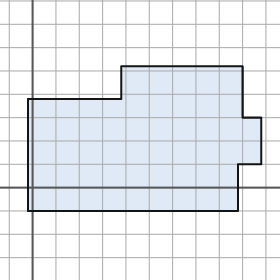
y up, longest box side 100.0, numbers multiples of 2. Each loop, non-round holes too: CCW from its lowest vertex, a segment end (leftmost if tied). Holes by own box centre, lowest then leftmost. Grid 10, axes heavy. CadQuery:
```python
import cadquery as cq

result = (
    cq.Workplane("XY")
    .moveTo(-2.0, -10.0)
    .lineTo(88.0, -10.0)
    .lineTo(88.0, 10.0)
    .lineTo(98.0, 10.0)
    .lineTo(98.0, 30.0)
    .lineTo(90.0, 30.0)
    .lineTo(90.0, 52.0)
    .lineTo(38.0, 52.0)
    .lineTo(38.0, 38.0)
    .lineTo(-2.0, 38.0)
    .close()
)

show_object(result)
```